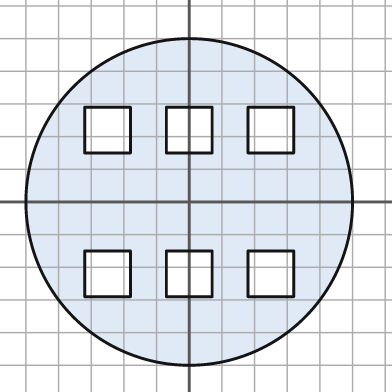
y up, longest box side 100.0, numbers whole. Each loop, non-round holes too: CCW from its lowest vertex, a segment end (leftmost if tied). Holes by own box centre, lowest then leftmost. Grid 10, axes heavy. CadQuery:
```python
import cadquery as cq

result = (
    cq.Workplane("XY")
    .moveTo(0.0, 0.0)
    .circle(50.0)
    .moveTo(-32.0, -29.0)
    .lineTo(-18.0, -29.0)
    .lineTo(-18.0, -15.0)
    .lineTo(-32.0, -15.0)
    .close()
    .moveTo(-7.0, -29.0)
    .lineTo(7.0, -29.0)
    .lineTo(7.0, -15.0)
    .lineTo(-7.0, -15.0)
    .close()
    .moveTo(18.0, -29.0)
    .lineTo(32.0, -29.0)
    .lineTo(32.0, -15.0)
    .lineTo(18.0, -15.0)
    .close()
    .moveTo(-32.0, 15.0)
    .lineTo(-18.0, 15.0)
    .lineTo(-18.0, 29.0)
    .lineTo(-32.0, 29.0)
    .close()
    .moveTo(-7.0, 15.0)
    .lineTo(7.0, 15.0)
    .lineTo(7.0, 29.0)
    .lineTo(-7.0, 29.0)
    .close()
    .moveTo(18.0, 15.0)
    .lineTo(32.0, 15.0)
    .lineTo(32.0, 29.0)
    .lineTo(18.0, 29.0)
    .close()
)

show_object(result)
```